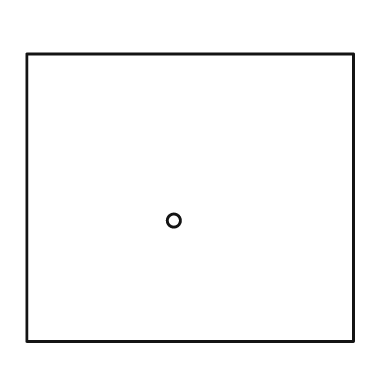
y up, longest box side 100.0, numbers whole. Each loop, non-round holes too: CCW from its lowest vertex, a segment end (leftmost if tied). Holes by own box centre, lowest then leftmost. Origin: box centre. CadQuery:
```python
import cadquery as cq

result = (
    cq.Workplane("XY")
    .moveTo(-50.0, -44.0)
    .lineTo(50.0, -44.0)
    .lineTo(50.0, 44.0)
    .lineTo(-50.0, 44.0)
    .close()
    .moveTo(-5.0, -7.0)
    .circle(2.0)
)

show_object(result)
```